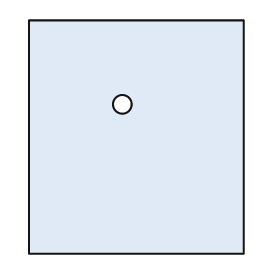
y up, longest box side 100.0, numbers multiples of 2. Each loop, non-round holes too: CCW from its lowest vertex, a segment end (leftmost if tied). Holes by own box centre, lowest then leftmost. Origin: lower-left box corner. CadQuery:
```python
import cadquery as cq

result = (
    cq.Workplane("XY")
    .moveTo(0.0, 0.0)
    .lineTo(92.0, 0.0)
    .lineTo(92.0, 100.0)
    .lineTo(0.0, 100.0)
    .close()
    .moveTo(40.0, 64.0)
    .circle(4.0)
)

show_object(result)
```